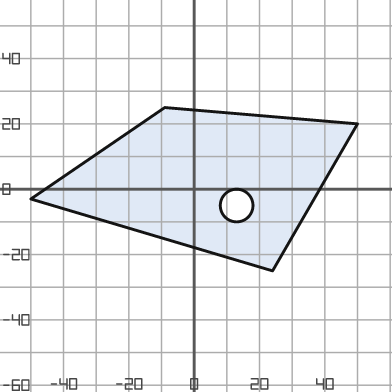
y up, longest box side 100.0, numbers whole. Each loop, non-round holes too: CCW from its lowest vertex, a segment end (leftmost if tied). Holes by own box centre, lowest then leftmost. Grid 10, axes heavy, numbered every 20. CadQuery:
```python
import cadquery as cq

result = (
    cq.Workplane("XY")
    .moveTo(24.0, -25.0)
    .lineTo(50.0, 20.0)
    .lineTo(-9.0, 25.0)
    .lineTo(-50.0, -3.0)
    .close()
    .moveTo(13.0, -5.0)
    .circle(5.0)
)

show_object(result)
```